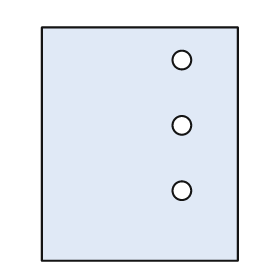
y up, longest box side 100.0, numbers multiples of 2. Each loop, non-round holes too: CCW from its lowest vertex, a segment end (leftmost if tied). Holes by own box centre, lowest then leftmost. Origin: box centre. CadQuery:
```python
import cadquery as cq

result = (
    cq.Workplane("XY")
    .moveTo(-42.0, -50.0)
    .lineTo(42.0, -50.0)
    .lineTo(42.0, 50.0)
    .lineTo(-42.0, 50.0)
    .close()
    .moveTo(18.0, -20.0)
    .circle(4.0)
    .moveTo(18.0, 8.0)
    .circle(4.0)
    .moveTo(18.0, 36.0)
    .circle(4.0)
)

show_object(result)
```